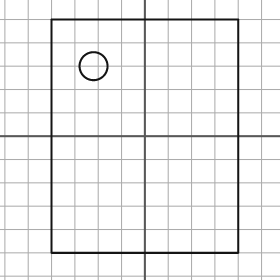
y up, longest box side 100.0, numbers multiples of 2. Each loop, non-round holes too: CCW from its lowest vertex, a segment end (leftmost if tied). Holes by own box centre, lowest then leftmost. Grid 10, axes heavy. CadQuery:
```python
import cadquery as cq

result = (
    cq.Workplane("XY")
    .moveTo(-40.0, -50.0)
    .lineTo(40.0, -50.0)
    .lineTo(40.0, 50.0)
    .lineTo(-40.0, 50.0)
    .close()
    .moveTo(-22.0, 30.0)
    .circle(6.0)
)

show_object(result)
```